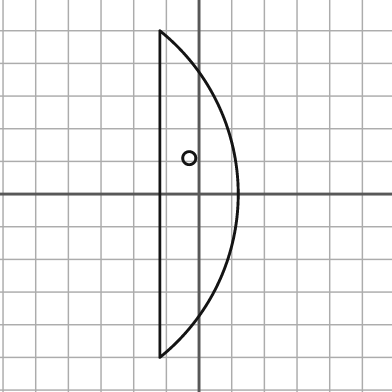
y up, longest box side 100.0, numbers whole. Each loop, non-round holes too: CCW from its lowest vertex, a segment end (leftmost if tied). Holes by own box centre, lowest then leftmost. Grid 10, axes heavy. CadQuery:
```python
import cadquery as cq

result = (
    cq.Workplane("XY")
    .moveTo(-12.0, -50.0)
    .threePointArc((12.0, 0.0), (-12.0, 50.0))
    .close()
    .moveTo(-3.0, 11.0)
    .circle(2.0)
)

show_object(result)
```